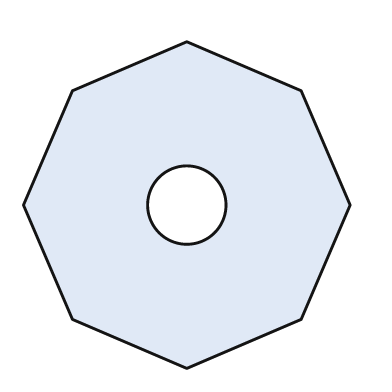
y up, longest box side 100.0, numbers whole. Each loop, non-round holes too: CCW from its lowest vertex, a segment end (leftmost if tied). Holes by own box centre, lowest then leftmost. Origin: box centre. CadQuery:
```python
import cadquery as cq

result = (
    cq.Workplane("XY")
    .moveTo(0.0, -50.0)
    .lineTo(35.0, -35.0)
    .lineTo(50.0, 0.0)
    .lineTo(35.0, 35.0)
    .lineTo(0.0, 50.0)
    .lineTo(-35.0, 35.0)
    .lineTo(-50.0, 0.0)
    .lineTo(-35.0, -35.0)
    .close()
    .moveTo(0.0, 0.0)
    .circle(12.0)
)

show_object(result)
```